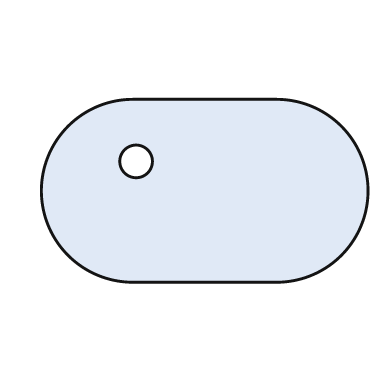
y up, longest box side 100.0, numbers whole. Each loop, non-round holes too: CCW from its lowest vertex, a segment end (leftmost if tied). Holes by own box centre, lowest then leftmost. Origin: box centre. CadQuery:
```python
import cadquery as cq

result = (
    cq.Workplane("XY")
    .moveTo(-22.0, -28.0)
    .lineTo(22.0, -28.0)
    .threePointArc((50.0, 0.0), (22.0, 28.0))
    .lineTo(-22.0, 28.0)
    .threePointArc((-50.0, 0.0), (-22.0, -28.0))
    .close()
    .moveTo(-21.0, 9.0)
    .circle(5.0)
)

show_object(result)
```